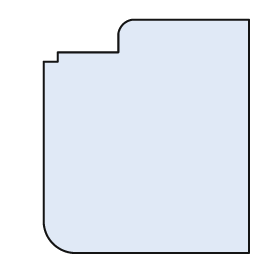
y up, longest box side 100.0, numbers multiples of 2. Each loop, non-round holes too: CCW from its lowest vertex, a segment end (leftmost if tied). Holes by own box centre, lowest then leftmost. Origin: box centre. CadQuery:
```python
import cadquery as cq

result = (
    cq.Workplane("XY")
    .moveTo(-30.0, -50.0)
    .lineTo(44.0, -50.0)
    .lineTo(44.0, 50.0)
    .lineTo(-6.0, 50.0)
    .threePointArc((-10.0, 48.0), (-12.0, 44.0))
    .lineTo(-12.0, 36.0)
    .lineTo(-38.0, 36.0)
    .lineTo(-38.0, 32.0)
    .lineTo(-44.0, 32.0)
    .lineTo(-44.0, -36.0)
    .threePointArc((-40.0, -46.0), (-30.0, -50.0))
    .close()
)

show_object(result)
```